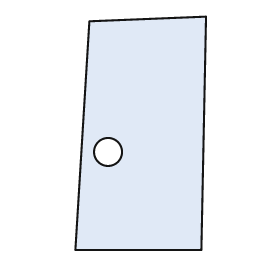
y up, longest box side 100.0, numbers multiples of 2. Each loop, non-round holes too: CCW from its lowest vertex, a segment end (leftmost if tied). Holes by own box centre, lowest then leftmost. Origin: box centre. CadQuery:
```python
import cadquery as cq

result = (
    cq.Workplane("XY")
    .moveTo(-28.0, -50.0)
    .lineTo(26.0, -50.0)
    .lineTo(28.0, 50.0)
    .lineTo(-22.0, 48.0)
    .close()
    .moveTo(-14.0, -8.0)
    .circle(6.0)
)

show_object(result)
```